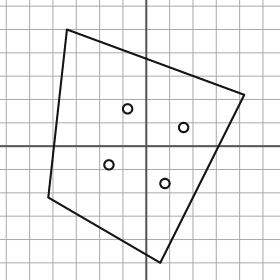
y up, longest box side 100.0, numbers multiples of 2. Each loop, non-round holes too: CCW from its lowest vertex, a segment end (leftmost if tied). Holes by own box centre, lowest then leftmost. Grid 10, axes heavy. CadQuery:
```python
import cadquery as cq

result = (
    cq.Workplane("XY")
    .moveTo(6.0, -50.0)
    .lineTo(42.0, 22.0)
    .lineTo(-34.0, 50.0)
    .lineTo(-42.0, -22.0)
    .close()
    .moveTo(8.0, -16.0)
    .circle(2.0)
    .moveTo(-16.0, -8.0)
    .circle(2.0)
    .moveTo(16.0, 8.0)
    .circle(2.0)
    .moveTo(-8.0, 16.0)
    .circle(2.0)
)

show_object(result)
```